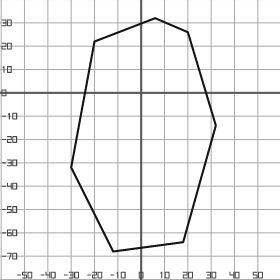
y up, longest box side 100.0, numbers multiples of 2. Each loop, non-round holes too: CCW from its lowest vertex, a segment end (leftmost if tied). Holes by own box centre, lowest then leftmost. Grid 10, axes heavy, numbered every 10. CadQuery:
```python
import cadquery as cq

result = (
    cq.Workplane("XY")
    .moveTo(-12.0, -68.0)
    .lineTo(18.0, -64.0)
    .lineTo(32.0, -14.0)
    .lineTo(20.0, 26.0)
    .lineTo(6.0, 32.0)
    .lineTo(-20.0, 22.0)
    .lineTo(-30.0, -32.0)
    .close()
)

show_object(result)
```